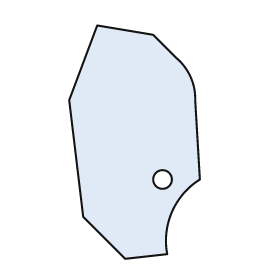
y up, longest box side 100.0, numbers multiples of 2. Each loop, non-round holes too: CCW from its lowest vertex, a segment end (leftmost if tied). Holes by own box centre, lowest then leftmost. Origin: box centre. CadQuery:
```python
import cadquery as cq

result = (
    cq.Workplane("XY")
    .moveTo(-4.0, -50.0)
    .lineTo(14.0, -48.0)
    .threePointArc((16.0, -30.0), (28.0, -16.0))
    .lineTo(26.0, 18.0)
    .threePointArc((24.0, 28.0), (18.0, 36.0))
    .lineTo(8.0, 46.0)
    .lineTo(-16.0, 50.0)
    .lineTo(-28.0, 18.0)
    .lineTo(-22.0, -32.0)
    .close()
    .moveTo(12.0, -16.0)
    .circle(4.0)
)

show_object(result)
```